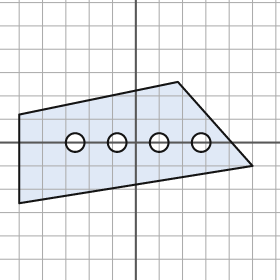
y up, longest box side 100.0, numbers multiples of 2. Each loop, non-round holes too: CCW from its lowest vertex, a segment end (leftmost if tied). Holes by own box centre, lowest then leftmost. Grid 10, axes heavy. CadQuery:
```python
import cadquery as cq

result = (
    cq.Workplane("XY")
    .moveTo(-50.0, -26.0)
    .lineTo(50.0, -10.0)
    .lineTo(18.0, 26.0)
    .lineTo(-50.0, 12.0)
    .close()
    .moveTo(-26.0, 0.0)
    .circle(4.0)
    .moveTo(-8.0, 0.0)
    .circle(4.0)
    .moveTo(10.0, 0.0)
    .circle(4.0)
    .moveTo(28.0, 0.0)
    .circle(4.0)
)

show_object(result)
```